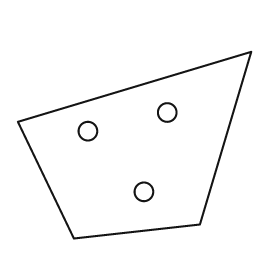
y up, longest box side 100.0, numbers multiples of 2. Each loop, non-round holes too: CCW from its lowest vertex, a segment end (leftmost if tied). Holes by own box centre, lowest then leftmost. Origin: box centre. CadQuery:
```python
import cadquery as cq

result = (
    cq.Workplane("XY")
    .moveTo(-26.0, -40.0)
    .lineTo(28.0, -34.0)
    .lineTo(50.0, 40.0)
    .lineTo(-50.0, 10.0)
    .close()
    .moveTo(4.0, -20.0)
    .circle(4.0)
    .moveTo(-20.0, 6.0)
    .circle(4.0)
    .moveTo(14.0, 14.0)
    .circle(4.0)
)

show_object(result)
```